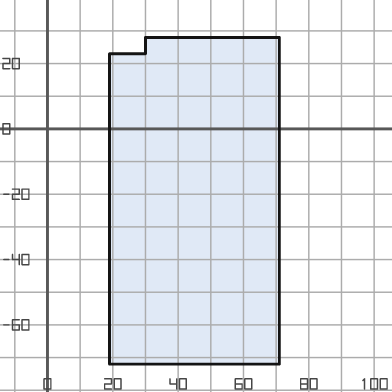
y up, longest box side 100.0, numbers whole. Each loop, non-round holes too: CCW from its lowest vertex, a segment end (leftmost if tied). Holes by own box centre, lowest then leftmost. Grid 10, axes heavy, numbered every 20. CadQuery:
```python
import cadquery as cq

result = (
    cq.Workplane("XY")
    .moveTo(19.0, -72.0)
    .lineTo(71.0, -72.0)
    .lineTo(71.0, 28.0)
    .lineTo(30.0, 28.0)
    .lineTo(30.0, 23.0)
    .lineTo(19.0, 23.0)
    .close()
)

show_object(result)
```